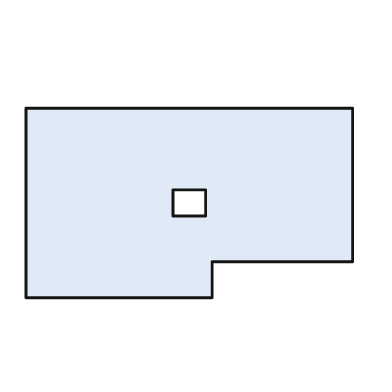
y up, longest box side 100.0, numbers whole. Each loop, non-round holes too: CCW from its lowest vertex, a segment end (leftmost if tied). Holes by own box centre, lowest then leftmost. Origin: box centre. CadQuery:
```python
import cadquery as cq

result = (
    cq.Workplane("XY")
    .moveTo(-50.0, -29.0)
    .lineTo(7.0, -29.0)
    .lineTo(7.0, -18.0)
    .lineTo(50.0, -18.0)
    .lineTo(50.0, 29.0)
    .lineTo(-50.0, 29.0)
    .close()
    .moveTo(-5.0, -4.0)
    .lineTo(5.0, -4.0)
    .lineTo(5.0, 4.0)
    .lineTo(-5.0, 4.0)
    .close()
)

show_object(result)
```